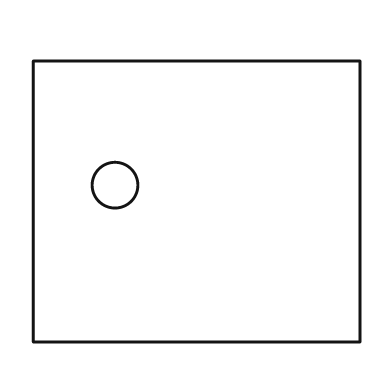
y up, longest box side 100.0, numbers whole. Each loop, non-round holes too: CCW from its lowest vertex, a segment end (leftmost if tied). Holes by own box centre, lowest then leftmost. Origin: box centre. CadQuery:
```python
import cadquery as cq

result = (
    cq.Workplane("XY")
    .moveTo(-50.0, -43.0)
    .lineTo(50.0, -43.0)
    .lineTo(50.0, 43.0)
    .lineTo(-50.0, 43.0)
    .close()
    .moveTo(-25.0, 5.0)
    .circle(7.0)
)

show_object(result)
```